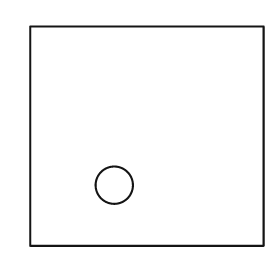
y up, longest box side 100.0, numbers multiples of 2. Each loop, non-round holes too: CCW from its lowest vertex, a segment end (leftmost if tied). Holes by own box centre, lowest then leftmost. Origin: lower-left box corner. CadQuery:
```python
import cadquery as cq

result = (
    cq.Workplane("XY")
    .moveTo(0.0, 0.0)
    .lineTo(100.0, 0.0)
    .lineTo(100.0, 94.0)
    .lineTo(0.0, 94.0)
    .close()
    .moveTo(36.0, 26.0)
    .circle(8.0)
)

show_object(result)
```